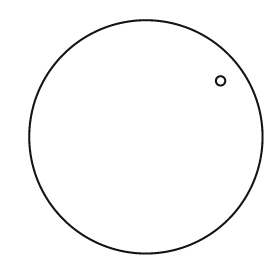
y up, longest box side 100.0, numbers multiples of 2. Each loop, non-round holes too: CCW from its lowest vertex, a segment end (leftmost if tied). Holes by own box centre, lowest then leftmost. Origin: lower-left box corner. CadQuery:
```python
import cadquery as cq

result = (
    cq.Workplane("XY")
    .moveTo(50.0, 50.0)
    .circle(50.0)
    .moveTo(82.0, 74.0)
    .circle(2.0)
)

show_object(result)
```